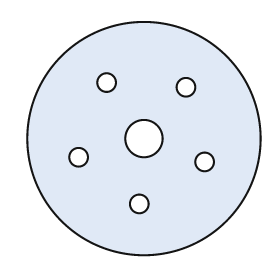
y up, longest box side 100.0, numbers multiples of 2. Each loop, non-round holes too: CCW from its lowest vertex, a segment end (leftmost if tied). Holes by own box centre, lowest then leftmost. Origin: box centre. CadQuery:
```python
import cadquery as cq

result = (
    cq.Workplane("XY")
    .moveTo(0.0, 0.0)
    .circle(50.0)
    .moveTo(-2.0, -28.0)
    .circle(4.0)
    .moveTo(26.0, -10.0)
    .circle(4.0)
    .moveTo(-28.0, -8.0)
    .circle(4.0)
    .moveTo(0.0, 0.0)
    .circle(8.0)
    .moveTo(18.0, 22.0)
    .circle(4.0)
    .moveTo(-16.0, 24.0)
    .circle(4.0)
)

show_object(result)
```